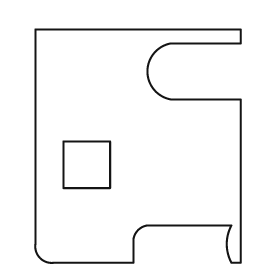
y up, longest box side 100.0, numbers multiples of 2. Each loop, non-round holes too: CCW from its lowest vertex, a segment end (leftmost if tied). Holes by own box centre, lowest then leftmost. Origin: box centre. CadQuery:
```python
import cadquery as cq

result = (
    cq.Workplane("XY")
    .moveTo(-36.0, -50.0)
    .lineTo(-2.0, -50.0)
    .lineTo(-2.0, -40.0)
    .threePointArc((0.0, -36.0), (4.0, -34.0))
    .lineTo(40.0, -34.0)
    .threePointArc((38.0, -42.0), (40.0, -50.0))
    .lineTo(44.0, -50.0)
    .lineTo(44.0, 20.0)
    .lineTo(14.0, 20.0)
    .threePointArc((4.0, 32.0), (14.0, 44.0))
    .lineTo(44.0, 44.0)
    .lineTo(44.0, 50.0)
    .lineTo(-44.0, 50.0)
    .lineTo(-44.0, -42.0)
    .threePointArc((-42.0, -48.0), (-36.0, -50.0))
    .close()
    .moveTo(-32.0, -18.0)
    .lineTo(-12.0, -18.0)
    .lineTo(-12.0, 2.0)
    .lineTo(-32.0, 2.0)
    .close()
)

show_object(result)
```